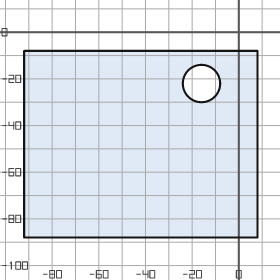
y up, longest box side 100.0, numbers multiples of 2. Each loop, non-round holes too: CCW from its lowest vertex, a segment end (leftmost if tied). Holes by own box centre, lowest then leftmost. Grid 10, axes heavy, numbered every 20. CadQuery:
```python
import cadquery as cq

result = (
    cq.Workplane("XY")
    .moveTo(-92.0, -88.0)
    .lineTo(8.0, -88.0)
    .lineTo(8.0, -8.0)
    .lineTo(-92.0, -8.0)
    .close()
    .moveTo(-16.0, -22.0)
    .circle(8.0)
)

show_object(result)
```